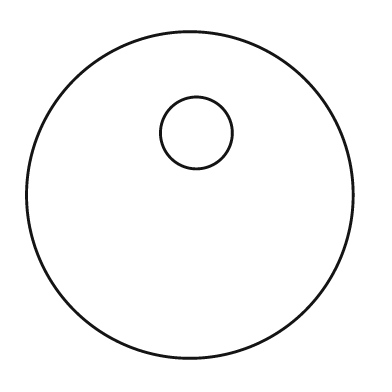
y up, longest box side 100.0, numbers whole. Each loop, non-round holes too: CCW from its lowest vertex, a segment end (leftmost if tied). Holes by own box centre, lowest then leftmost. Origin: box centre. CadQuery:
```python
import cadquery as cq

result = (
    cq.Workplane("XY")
    .moveTo(0.0, 0.0)
    .circle(50.0)
    .moveTo(2.0, 19.0)
    .circle(11.0)
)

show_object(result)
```